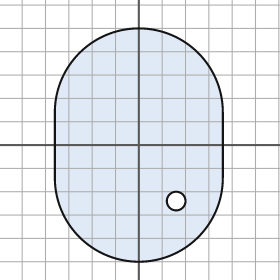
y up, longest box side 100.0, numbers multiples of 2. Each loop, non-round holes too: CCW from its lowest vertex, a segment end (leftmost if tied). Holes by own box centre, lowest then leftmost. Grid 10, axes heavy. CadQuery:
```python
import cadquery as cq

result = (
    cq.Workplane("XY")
    .moveTo(-36.0, -14.0)
    .threePointArc((0.0, -50.0), (36.0, -14.0))
    .lineTo(36.0, 14.0)
    .threePointArc((0.0, 50.0), (-36.0, 14.0))
    .close()
    .moveTo(16.0, -24.0)
    .circle(4.0)
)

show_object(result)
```